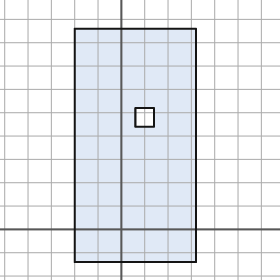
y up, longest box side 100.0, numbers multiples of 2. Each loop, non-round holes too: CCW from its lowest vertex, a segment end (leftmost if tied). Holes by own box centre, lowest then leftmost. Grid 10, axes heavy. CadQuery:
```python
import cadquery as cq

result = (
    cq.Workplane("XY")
    .moveTo(-20.0, -14.0)
    .lineTo(32.0, -14.0)
    .lineTo(32.0, 86.0)
    .lineTo(-20.0, 86.0)
    .close()
    .moveTo(6.0, 44.0)
    .lineTo(14.0, 44.0)
    .lineTo(14.0, 52.0)
    .lineTo(6.0, 52.0)
    .close()
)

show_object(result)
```